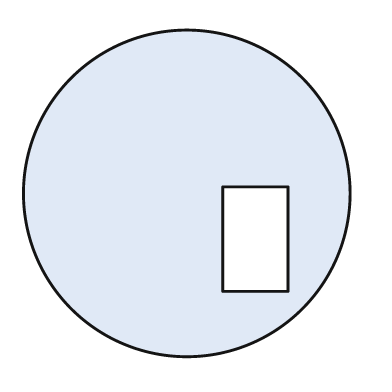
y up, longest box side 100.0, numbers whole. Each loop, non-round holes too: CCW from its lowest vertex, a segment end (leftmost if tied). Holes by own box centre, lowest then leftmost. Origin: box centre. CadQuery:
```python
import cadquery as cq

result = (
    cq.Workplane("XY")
    .moveTo(0.0, 0.0)
    .circle(50.0)
    .moveTo(11.0, -30.0)
    .lineTo(31.0, -30.0)
    .lineTo(31.0, 2.0)
    .lineTo(11.0, 2.0)
    .close()
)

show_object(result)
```